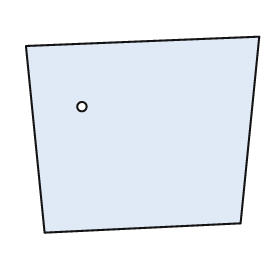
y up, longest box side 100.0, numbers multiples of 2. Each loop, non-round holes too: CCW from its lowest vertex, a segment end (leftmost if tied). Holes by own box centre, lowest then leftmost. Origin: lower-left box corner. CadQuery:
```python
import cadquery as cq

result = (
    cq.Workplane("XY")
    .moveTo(8.0, 0.0)
    .lineTo(92.0, 4.0)
    .lineTo(100.0, 84.0)
    .lineTo(0.0, 80.0)
    .close()
    .moveTo(24.0, 54.0)
    .circle(2.0)
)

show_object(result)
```